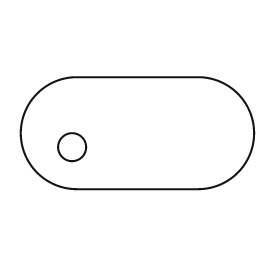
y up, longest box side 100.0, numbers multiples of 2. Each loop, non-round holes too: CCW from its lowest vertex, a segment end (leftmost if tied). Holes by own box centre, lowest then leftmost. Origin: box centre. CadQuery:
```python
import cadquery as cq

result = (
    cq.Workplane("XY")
    .moveTo(-26.0, -24.0)
    .lineTo(26.0, -24.0)
    .threePointArc((50.0, 0.0), (26.0, 24.0))
    .lineTo(-26.0, 24.0)
    .threePointArc((-50.0, 0.0), (-26.0, -24.0))
    .close()
    .moveTo(-28.0, -6.0)
    .circle(6.0)
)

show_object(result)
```